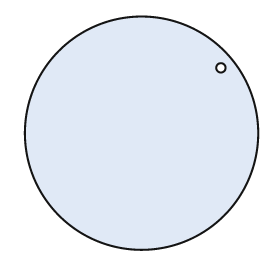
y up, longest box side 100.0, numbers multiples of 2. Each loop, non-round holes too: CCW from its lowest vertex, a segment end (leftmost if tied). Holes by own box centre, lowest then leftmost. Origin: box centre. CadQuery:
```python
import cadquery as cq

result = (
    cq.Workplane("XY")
    .moveTo(0.0, 0.0)
    .circle(50.0)
    .moveTo(34.0, 28.0)
    .circle(2.0)
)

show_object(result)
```